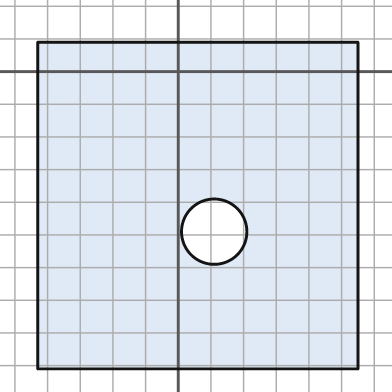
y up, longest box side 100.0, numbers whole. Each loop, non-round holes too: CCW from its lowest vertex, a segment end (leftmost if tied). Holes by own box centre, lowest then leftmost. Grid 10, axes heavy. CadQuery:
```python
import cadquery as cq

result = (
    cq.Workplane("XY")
    .moveTo(-43.0, -91.0)
    .lineTo(55.0, -91.0)
    .lineTo(55.0, 9.0)
    .lineTo(-43.0, 9.0)
    .close()
    .moveTo(11.0, -49.0)
    .circle(10.0)
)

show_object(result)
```